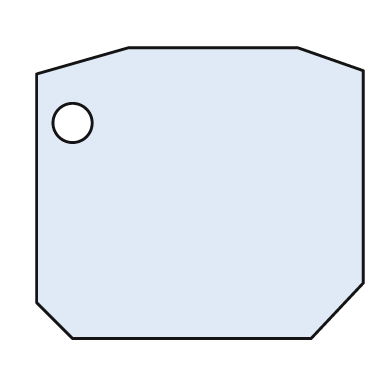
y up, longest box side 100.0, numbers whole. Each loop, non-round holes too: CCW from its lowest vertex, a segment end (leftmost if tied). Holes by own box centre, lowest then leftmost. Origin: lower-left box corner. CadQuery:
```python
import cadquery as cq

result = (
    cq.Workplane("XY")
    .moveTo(11.0, 0.0)
    .lineTo(84.0, 0.0)
    .lineTo(100.0, 17.0)
    .lineTo(100.0, 82.0)
    .lineTo(80.0, 89.0)
    .lineTo(28.0, 89.0)
    .lineTo(0.0, 81.0)
    .lineTo(0.0, 11.0)
    .close()
    .moveTo(11.0, 66.0)
    .circle(6.0)
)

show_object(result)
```